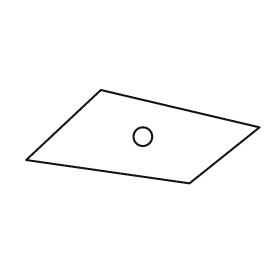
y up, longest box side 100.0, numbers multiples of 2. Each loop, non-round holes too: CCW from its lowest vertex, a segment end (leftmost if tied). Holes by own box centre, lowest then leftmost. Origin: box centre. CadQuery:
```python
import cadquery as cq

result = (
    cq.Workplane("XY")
    .moveTo(20.0, -20.0)
    .lineTo(50.0, 4.0)
    .lineTo(-18.0, 20.0)
    .lineTo(-50.0, -10.0)
    .close()
    .moveTo(0.0, 0.0)
    .circle(4.0)
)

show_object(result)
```